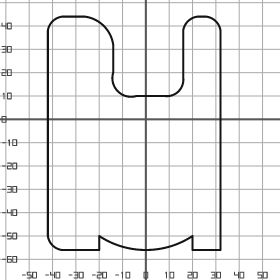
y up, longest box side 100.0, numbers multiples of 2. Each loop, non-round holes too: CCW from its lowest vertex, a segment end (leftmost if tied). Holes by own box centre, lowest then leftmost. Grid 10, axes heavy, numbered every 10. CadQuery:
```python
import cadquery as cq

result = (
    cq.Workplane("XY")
    .moveTo(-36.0, -56.0)
    .lineTo(-20.0, -56.0)
    .lineTo(-20.0, -50.0)
    .threePointArc((0.0, -56.0), (20.0, -50.0))
    .lineTo(20.0, -56.0)
    .lineTo(32.0, -56.0)
    .lineTo(32.0, 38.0)
    .threePointArc((30.0, 42.0), (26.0, 44.0))
    .lineTo(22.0, 44.0)
    .threePointArc((18.0, 42.0), (16.0, 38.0))
    .lineTo(16.0, 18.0)
    .threePointArc((14.0, 12.0), (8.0, 10.0))
    .lineTo(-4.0, 10.0)
    .threePointArc((-12.0, 12.0), (-14.0, 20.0))
    .lineTo(-14.0, 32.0)
    .threePointArc((-18.0, 40.0), (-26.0, 44.0))
    .lineTo(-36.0, 44.0)
    .threePointArc((-40.0, 42.0), (-42.0, 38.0))
    .lineTo(-42.0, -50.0)
    .threePointArc((-40.0, -54.0), (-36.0, -56.0))
    .close()
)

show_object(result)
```